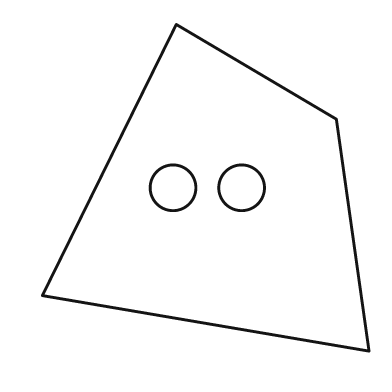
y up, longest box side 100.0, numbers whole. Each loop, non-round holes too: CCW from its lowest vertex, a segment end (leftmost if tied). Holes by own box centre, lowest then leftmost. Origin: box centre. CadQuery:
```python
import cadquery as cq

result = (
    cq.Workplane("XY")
    .moveTo(50.0, -50.0)
    .lineTo(40.0, 21.0)
    .lineTo(-9.0, 50.0)
    .lineTo(-50.0, -33.0)
    .close()
    .moveTo(-10.0, 0.0)
    .circle(7.0)
    .moveTo(11.0, 0.0)
    .circle(7.0)
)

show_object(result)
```